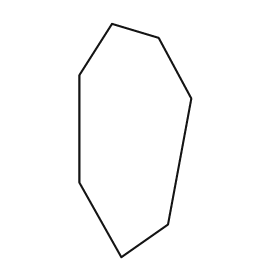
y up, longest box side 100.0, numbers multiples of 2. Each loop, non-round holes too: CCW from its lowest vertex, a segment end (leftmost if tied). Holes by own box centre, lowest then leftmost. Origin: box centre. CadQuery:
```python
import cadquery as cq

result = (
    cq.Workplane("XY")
    .moveTo(-6.0, -50.0)
    .lineTo(14.0, -36.0)
    .lineTo(24.0, 18.0)
    .lineTo(10.0, 44.0)
    .lineTo(-10.0, 50.0)
    .lineTo(-24.0, 28.0)
    .lineTo(-24.0, -18.0)
    .close()
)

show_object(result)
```